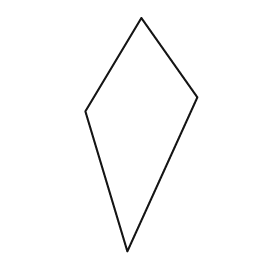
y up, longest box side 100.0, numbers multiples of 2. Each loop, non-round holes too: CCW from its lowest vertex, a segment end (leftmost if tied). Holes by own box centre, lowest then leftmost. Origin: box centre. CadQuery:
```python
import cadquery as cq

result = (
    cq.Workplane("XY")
    .moveTo(-6.0, -50.0)
    .lineTo(24.0, 16.0)
    .lineTo(0.0, 50.0)
    .lineTo(-24.0, 10.0)
    .close()
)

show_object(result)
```